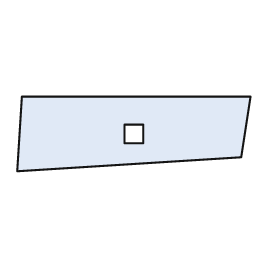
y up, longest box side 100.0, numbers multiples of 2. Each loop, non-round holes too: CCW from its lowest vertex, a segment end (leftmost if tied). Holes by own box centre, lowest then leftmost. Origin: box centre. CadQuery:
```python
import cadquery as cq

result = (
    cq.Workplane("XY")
    .moveTo(-50.0, -16.0)
    .lineTo(46.0, -10.0)
    .lineTo(50.0, 16.0)
    .lineTo(-48.0, 16.0)
    .close()
    .moveTo(-4.0, -4.0)
    .lineTo(4.0, -4.0)
    .lineTo(4.0, 4.0)
    .lineTo(-4.0, 4.0)
    .close()
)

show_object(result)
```